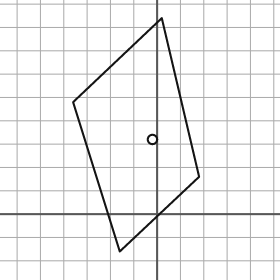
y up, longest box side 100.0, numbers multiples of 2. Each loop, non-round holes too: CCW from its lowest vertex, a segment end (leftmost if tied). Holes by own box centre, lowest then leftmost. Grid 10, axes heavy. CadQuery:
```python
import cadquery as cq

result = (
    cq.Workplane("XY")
    .moveTo(-16.0, -16.0)
    .lineTo(18.0, 16.0)
    .lineTo(2.0, 84.0)
    .lineTo(-36.0, 48.0)
    .close()
    .moveTo(-2.0, 32.0)
    .circle(2.0)
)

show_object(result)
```